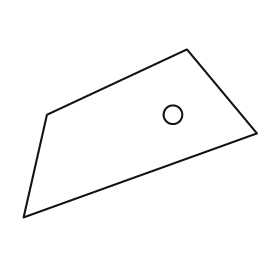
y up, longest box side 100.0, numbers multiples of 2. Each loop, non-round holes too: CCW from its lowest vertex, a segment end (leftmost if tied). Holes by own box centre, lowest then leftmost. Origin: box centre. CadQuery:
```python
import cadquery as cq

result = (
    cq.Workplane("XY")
    .moveTo(-50.0, -36.0)
    .lineTo(50.0, 0.0)
    .lineTo(20.0, 36.0)
    .lineTo(-40.0, 8.0)
    .close()
    .moveTo(14.0, 8.0)
    .circle(4.0)
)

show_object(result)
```